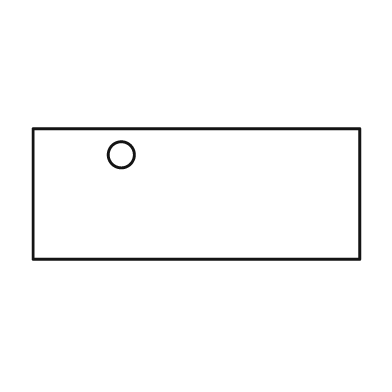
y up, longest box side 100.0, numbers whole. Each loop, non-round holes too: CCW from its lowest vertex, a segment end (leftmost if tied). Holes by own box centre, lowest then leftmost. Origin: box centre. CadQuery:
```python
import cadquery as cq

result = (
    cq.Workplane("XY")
    .moveTo(-50.0, -20.0)
    .lineTo(50.0, -20.0)
    .lineTo(50.0, 20.0)
    .lineTo(-50.0, 20.0)
    .close()
    .moveTo(-23.0, 12.0)
    .circle(4.0)
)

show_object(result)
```